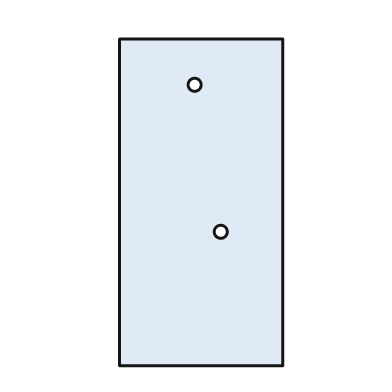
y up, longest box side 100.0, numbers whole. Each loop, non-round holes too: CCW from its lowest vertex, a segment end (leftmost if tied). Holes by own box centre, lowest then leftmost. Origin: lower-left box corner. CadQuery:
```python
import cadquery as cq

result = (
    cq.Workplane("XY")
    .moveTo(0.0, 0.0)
    .lineTo(50.0, 0.0)
    .lineTo(50.0, 100.0)
    .lineTo(0.0, 100.0)
    .close()
    .moveTo(31.0, 41.0)
    .circle(2.0)
    .moveTo(23.0, 86.0)
    .circle(2.0)
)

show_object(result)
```